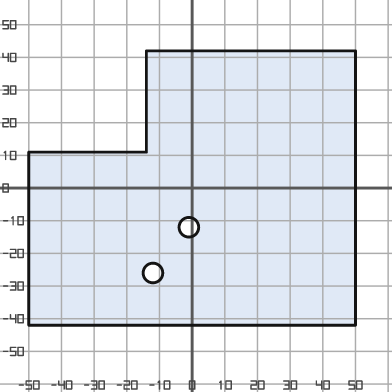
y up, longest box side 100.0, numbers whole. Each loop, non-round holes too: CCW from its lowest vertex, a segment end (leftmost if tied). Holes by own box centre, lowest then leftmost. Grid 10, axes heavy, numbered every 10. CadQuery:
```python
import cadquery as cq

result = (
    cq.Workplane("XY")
    .moveTo(-50.0, -42.0)
    .lineTo(50.0, -42.0)
    .lineTo(50.0, 42.0)
    .lineTo(-14.0, 42.0)
    .lineTo(-14.0, 11.0)
    .lineTo(-50.0, 11.0)
    .close()
    .moveTo(-12.0, -26.0)
    .circle(3.0)
    .moveTo(-1.0, -12.0)
    .circle(3.0)
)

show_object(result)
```